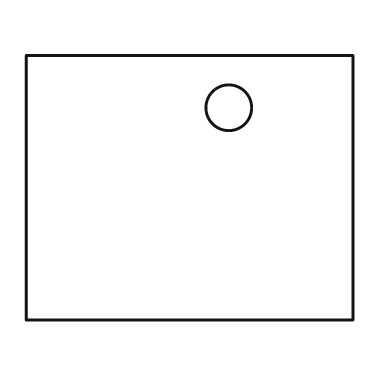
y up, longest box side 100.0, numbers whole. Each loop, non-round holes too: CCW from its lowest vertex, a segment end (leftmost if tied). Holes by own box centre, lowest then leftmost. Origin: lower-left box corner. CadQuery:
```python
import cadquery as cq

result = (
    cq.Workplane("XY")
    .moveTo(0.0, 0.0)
    .lineTo(100.0, 0.0)
    .lineTo(100.0, 81.0)
    .lineTo(0.0, 81.0)
    .close()
    .moveTo(62.0, 65.0)
    .circle(7.0)
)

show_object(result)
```